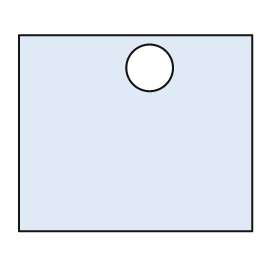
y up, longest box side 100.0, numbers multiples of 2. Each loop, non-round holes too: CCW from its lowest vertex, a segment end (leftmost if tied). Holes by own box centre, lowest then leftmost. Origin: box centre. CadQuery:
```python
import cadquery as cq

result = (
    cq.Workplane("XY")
    .moveTo(-50.0, -42.0)
    .lineTo(50.0, -42.0)
    .lineTo(50.0, 42.0)
    .lineTo(-50.0, 42.0)
    .close()
    .moveTo(6.0, 28.0)
    .circle(10.0)
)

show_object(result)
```